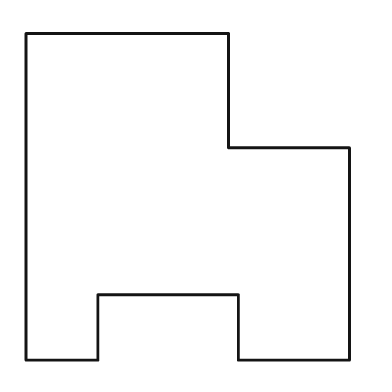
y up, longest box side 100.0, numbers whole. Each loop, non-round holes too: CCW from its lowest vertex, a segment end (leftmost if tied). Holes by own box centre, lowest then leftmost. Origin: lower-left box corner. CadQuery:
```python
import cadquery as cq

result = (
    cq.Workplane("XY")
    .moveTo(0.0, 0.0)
    .lineTo(22.0, 0.0)
    .lineTo(22.0, 20.0)
    .lineTo(65.0, 20.0)
    .lineTo(65.0, 0.0)
    .lineTo(99.0, 0.0)
    .lineTo(99.0, 65.0)
    .lineTo(62.0, 65.0)
    .lineTo(62.0, 100.0)
    .lineTo(0.0, 100.0)
    .close()
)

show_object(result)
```